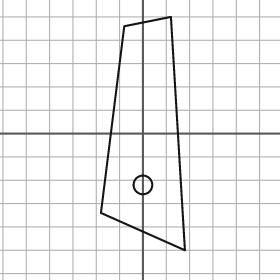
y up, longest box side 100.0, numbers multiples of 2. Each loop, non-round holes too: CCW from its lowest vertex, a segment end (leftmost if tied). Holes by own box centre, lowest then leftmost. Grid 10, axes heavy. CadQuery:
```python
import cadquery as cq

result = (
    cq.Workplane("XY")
    .moveTo(18.0, -50.0)
    .lineTo(12.0, 50.0)
    .lineTo(-8.0, 46.0)
    .lineTo(-18.0, -34.0)
    .close()
    .moveTo(0.0, -22.0)
    .circle(4.0)
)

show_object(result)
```